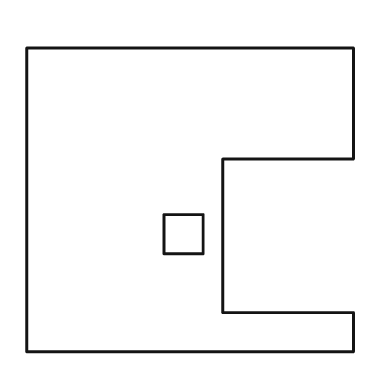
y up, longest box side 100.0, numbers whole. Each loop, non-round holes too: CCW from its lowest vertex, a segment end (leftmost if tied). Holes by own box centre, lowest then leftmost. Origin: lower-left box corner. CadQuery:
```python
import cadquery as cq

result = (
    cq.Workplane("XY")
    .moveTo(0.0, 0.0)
    .lineTo(100.0, 0.0)
    .lineTo(100.0, 12.0)
    .lineTo(60.0, 12.0)
    .lineTo(60.0, 59.0)
    .lineTo(100.0, 59.0)
    .lineTo(100.0, 93.0)
    .lineTo(0.0, 93.0)
    .close()
    .moveTo(42.0, 30.0)
    .lineTo(54.0, 30.0)
    .lineTo(54.0, 42.0)
    .lineTo(42.0, 42.0)
    .close()
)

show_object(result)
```